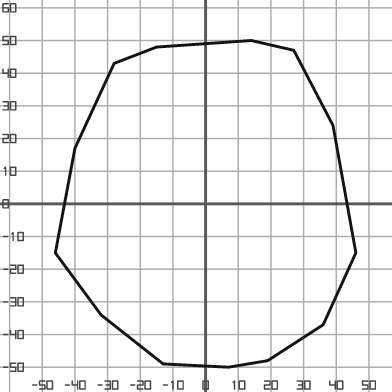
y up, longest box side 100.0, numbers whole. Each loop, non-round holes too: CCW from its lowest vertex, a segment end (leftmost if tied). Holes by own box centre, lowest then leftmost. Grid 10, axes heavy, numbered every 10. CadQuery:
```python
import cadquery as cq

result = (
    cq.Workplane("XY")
    .moveTo(7.0, -50.0)
    .lineTo(19.0, -48.0)
    .lineTo(36.0, -37.0)
    .lineTo(46.0, -15.0)
    .lineTo(39.0, 24.0)
    .lineTo(27.0, 47.0)
    .lineTo(14.0, 50.0)
    .lineTo(-15.0, 48.0)
    .lineTo(-28.0, 43.0)
    .lineTo(-40.0, 17.0)
    .lineTo(-46.0, -15.0)
    .lineTo(-32.0, -34.0)
    .lineTo(-13.0, -49.0)
    .close()
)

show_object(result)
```